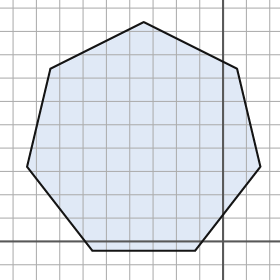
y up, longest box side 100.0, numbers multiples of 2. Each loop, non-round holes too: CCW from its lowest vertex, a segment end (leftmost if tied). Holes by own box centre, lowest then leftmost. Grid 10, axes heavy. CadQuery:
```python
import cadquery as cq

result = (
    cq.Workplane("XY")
    .moveTo(-56.0, -4.0)
    .lineTo(-12.0, -4.0)
    .lineTo(16.0, 32.0)
    .lineTo(6.0, 74.0)
    .lineTo(-34.0, 94.0)
    .lineTo(-74.0, 74.0)
    .lineTo(-84.0, 32.0)
    .close()
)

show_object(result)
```